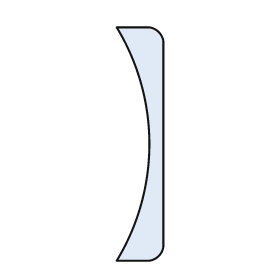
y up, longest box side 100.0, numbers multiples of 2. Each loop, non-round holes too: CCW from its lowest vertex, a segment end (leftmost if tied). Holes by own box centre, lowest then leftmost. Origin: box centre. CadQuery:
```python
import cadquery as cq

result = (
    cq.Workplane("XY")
    .moveTo(-10.0, -50.0)
    .lineTo(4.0, -50.0)
    .threePointArc((8.0, -48.0), (10.0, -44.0))
    .lineTo(10.0, 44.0)
    .threePointArc((8.0, 48.0), (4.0, 50.0))
    .lineTo(-10.0, 50.0)
    .threePointArc((4.0, 0.0), (-10.0, -50.0))
    .close()
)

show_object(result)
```